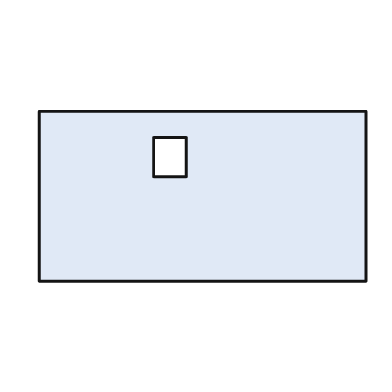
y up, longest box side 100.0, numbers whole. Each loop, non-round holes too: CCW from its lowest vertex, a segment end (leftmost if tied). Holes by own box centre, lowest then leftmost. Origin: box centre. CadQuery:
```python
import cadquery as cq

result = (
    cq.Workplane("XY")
    .moveTo(-50.0, -26.0)
    .lineTo(50.0, -26.0)
    .lineTo(50.0, 26.0)
    .lineTo(-50.0, 26.0)
    .close()
    .moveTo(-15.0, 6.0)
    .lineTo(-5.0, 6.0)
    .lineTo(-5.0, 18.0)
    .lineTo(-15.0, 18.0)
    .close()
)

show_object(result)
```